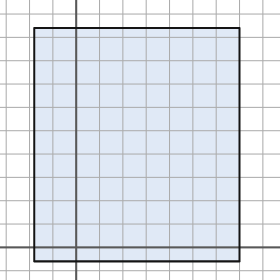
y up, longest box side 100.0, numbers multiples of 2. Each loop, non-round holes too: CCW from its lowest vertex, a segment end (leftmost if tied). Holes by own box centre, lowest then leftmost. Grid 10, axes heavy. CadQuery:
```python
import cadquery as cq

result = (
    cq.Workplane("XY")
    .moveTo(-18.0, -6.0)
    .lineTo(70.0, -6.0)
    .lineTo(70.0, 94.0)
    .lineTo(-18.0, 94.0)
    .close()
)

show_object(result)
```